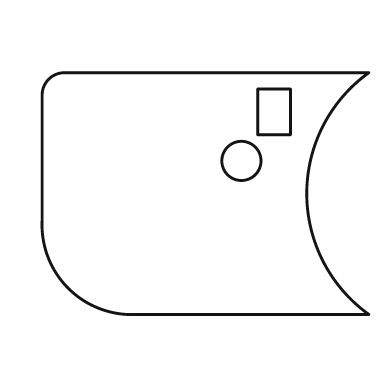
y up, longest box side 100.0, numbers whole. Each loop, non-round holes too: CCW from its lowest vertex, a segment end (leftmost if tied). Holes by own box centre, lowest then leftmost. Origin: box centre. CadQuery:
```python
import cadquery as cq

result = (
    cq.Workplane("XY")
    .moveTo(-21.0, -37.0)
    .lineTo(50.0, -37.0)
    .threePointArc((31.0, 0.0), (50.0, 37.0))
    .lineTo(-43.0, 37.0)
    .threePointArc((-48.0, 35.0), (-50.0, 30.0))
    .lineTo(-50.0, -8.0)
    .threePointArc((-42.0, -29.0), (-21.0, -37.0))
    .close()
    .moveTo(11.0, 10.0)
    .circle(6.0)
    .moveTo(16.0, 18.0)
    .lineTo(26.0, 18.0)
    .lineTo(26.0, 32.0)
    .lineTo(16.0, 32.0)
    .close()
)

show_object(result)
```